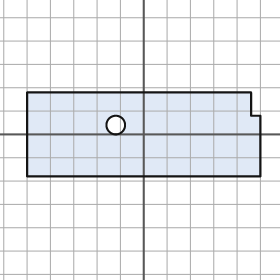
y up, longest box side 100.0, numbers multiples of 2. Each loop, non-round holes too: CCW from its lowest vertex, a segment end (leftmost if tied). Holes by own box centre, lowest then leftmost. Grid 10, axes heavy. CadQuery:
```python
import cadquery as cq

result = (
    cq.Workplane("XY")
    .moveTo(-50.0, -18.0)
    .lineTo(50.0, -18.0)
    .lineTo(50.0, 8.0)
    .lineTo(46.0, 8.0)
    .lineTo(46.0, 18.0)
    .lineTo(-50.0, 18.0)
    .close()
    .moveTo(-12.0, 4.0)
    .circle(4.0)
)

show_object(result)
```